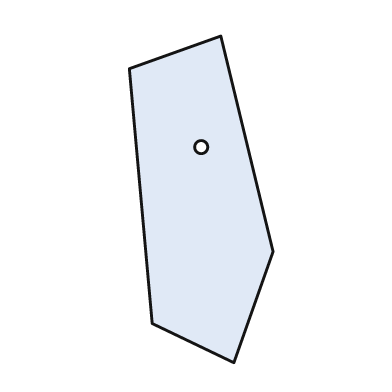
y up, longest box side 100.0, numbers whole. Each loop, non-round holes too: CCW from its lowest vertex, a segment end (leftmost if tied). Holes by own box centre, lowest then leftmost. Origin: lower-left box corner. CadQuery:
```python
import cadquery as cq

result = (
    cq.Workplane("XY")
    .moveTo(32.0, 0.0)
    .lineTo(44.0, 34.0)
    .lineTo(28.0, 100.0)
    .lineTo(0.0, 90.0)
    .lineTo(7.0, 12.0)
    .close()
    .moveTo(22.0, 66.0)
    .circle(2.0)
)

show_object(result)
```